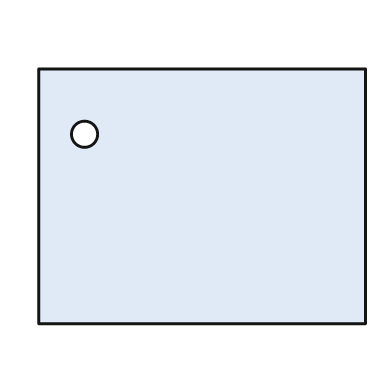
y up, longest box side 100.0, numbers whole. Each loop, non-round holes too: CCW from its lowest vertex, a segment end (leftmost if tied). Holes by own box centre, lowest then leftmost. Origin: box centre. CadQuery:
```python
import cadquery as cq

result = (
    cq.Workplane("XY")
    .moveTo(-50.0, -39.0)
    .lineTo(50.0, -39.0)
    .lineTo(50.0, 39.0)
    .lineTo(-50.0, 39.0)
    .close()
    .moveTo(-36.0, 19.0)
    .circle(4.0)
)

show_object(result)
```